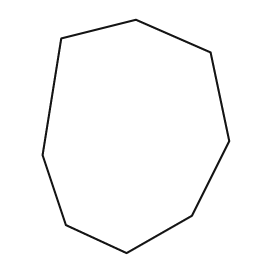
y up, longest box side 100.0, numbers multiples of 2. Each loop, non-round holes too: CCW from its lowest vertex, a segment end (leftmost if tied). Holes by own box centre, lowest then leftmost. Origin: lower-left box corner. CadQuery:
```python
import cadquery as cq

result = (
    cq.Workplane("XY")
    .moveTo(36.0, 0.0)
    .lineTo(64.0, 16.0)
    .lineTo(80.0, 48.0)
    .lineTo(72.0, 86.0)
    .lineTo(40.0, 100.0)
    .lineTo(8.0, 92.0)
    .lineTo(0.0, 42.0)
    .lineTo(10.0, 12.0)
    .close()
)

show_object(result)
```